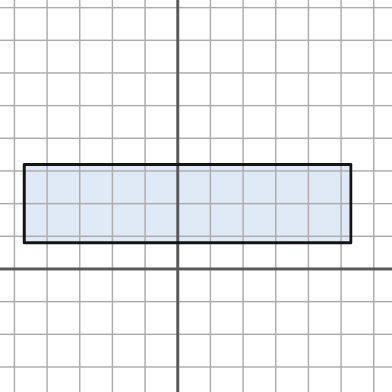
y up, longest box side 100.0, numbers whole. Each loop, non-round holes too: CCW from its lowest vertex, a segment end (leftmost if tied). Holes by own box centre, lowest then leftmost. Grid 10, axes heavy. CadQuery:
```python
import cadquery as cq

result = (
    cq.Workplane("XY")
    .moveTo(-47.0, 8.0)
    .lineTo(53.0, 8.0)
    .lineTo(53.0, 32.0)
    .lineTo(-47.0, 32.0)
    .close()
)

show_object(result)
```